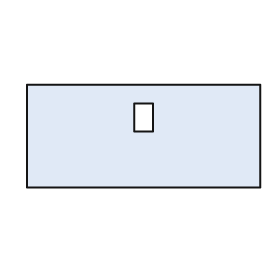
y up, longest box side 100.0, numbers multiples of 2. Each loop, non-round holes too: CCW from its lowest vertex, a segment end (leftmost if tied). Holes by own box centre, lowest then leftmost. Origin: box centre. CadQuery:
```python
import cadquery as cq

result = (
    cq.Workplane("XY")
    .moveTo(-50.0, -22.0)
    .lineTo(50.0, -22.0)
    .lineTo(50.0, 22.0)
    .lineTo(-50.0, 22.0)
    .close()
    .moveTo(-4.0, 2.0)
    .lineTo(4.0, 2.0)
    .lineTo(4.0, 14.0)
    .lineTo(-4.0, 14.0)
    .close()
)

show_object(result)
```